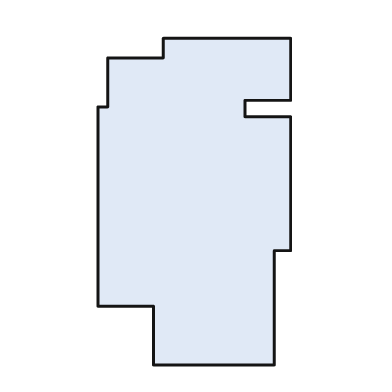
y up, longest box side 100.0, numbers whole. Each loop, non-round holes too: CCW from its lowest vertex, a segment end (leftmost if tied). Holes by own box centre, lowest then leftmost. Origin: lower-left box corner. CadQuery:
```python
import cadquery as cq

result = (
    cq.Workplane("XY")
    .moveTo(17.0, 0.0)
    .lineTo(54.0, 0.0)
    .lineTo(54.0, 35.0)
    .lineTo(59.0, 35.0)
    .lineTo(59.0, 76.0)
    .lineTo(45.0, 76.0)
    .lineTo(45.0, 81.0)
    .lineTo(59.0, 81.0)
    .lineTo(59.0, 100.0)
    .lineTo(20.0, 100.0)
    .lineTo(20.0, 94.0)
    .lineTo(3.0, 94.0)
    .lineTo(3.0, 79.0)
    .lineTo(0.0, 79.0)
    .lineTo(0.0, 18.0)
    .lineTo(17.0, 18.0)
    .close()
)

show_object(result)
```